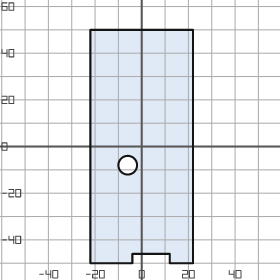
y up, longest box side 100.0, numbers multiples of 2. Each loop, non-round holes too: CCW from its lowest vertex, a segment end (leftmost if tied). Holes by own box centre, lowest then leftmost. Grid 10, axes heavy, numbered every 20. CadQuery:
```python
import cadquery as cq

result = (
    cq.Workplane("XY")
    .moveTo(-22.0, -50.0)
    .lineTo(-4.0, -50.0)
    .lineTo(-4.0, -46.0)
    .lineTo(12.0, -46.0)
    .lineTo(12.0, -50.0)
    .lineTo(22.0, -50.0)
    .lineTo(22.0, 50.0)
    .lineTo(-22.0, 50.0)
    .close()
    .moveTo(-6.0, -8.0)
    .circle(4.0)
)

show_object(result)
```